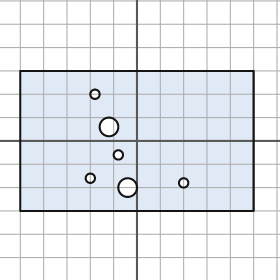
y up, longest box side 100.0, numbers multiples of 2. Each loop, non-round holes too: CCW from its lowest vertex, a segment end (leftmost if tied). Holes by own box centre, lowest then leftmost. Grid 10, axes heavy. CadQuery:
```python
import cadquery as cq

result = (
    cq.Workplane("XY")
    .moveTo(-50.0, -30.0)
    .lineTo(50.0, -30.0)
    .lineTo(50.0, 30.0)
    .lineTo(-50.0, 30.0)
    .close()
    .moveTo(-4.0, -20.0)
    .circle(4.0)
    .moveTo(20.0, -18.0)
    .circle(2.0)
    .moveTo(-20.0, -16.0)
    .circle(2.0)
    .moveTo(-8.0, -6.0)
    .circle(2.0)
    .moveTo(-12.0, 6.0)
    .circle(4.0)
    .moveTo(-18.0, 20.0)
    .circle(2.0)
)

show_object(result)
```